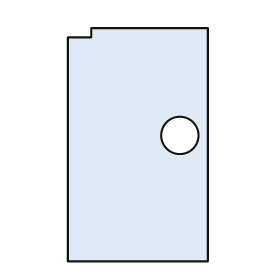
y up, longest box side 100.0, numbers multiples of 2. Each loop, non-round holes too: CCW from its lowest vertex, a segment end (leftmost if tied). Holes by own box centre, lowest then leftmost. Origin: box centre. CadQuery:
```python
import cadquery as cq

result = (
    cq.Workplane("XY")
    .moveTo(-30.0, -50.0)
    .lineTo(30.0, -50.0)
    .lineTo(30.0, 50.0)
    .lineTo(-20.0, 50.0)
    .lineTo(-20.0, 46.0)
    .lineTo(-30.0, 46.0)
    .close()
    .moveTo(18.0, 4.0)
    .circle(8.0)
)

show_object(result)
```